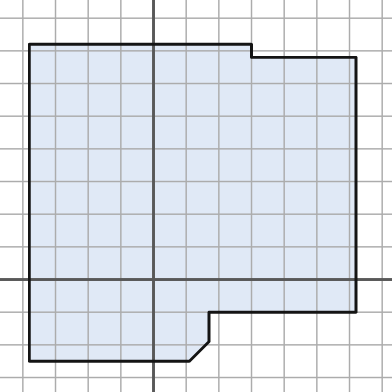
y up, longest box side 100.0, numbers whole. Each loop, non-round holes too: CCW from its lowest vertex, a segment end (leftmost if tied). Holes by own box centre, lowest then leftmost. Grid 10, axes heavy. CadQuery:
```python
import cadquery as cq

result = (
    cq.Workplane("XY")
    .moveTo(-38.0, -25.0)
    .lineTo(11.0, -25.0)
    .lineTo(17.0, -19.0)
    .lineTo(17.0, -10.0)
    .lineTo(62.0, -10.0)
    .lineTo(62.0, 68.0)
    .lineTo(30.0, 68.0)
    .lineTo(30.0, 72.0)
    .lineTo(-38.0, 72.0)
    .close()
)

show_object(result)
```